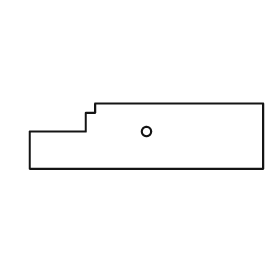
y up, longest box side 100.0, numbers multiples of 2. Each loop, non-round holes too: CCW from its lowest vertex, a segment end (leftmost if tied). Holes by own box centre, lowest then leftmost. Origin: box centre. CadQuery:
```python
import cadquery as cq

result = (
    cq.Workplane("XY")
    .moveTo(-50.0, -14.0)
    .lineTo(50.0, -14.0)
    .lineTo(50.0, 14.0)
    .lineTo(-22.0, 14.0)
    .lineTo(-22.0, 10.0)
    .lineTo(-26.0, 10.0)
    .lineTo(-26.0, 2.0)
    .lineTo(-50.0, 2.0)
    .close()
    .moveTo(0.0, 2.0)
    .circle(2.0)
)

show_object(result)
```